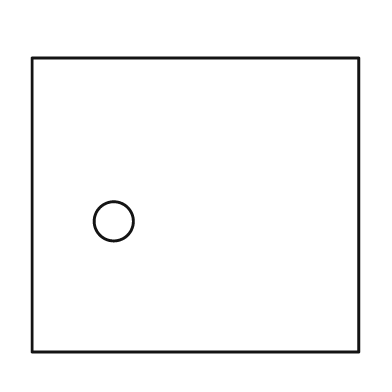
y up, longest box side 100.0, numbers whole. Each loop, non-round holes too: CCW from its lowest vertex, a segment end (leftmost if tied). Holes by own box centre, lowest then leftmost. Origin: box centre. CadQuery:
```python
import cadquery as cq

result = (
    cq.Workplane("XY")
    .moveTo(-50.0, -45.0)
    .lineTo(50.0, -45.0)
    .lineTo(50.0, 45.0)
    .lineTo(-50.0, 45.0)
    .close()
    .moveTo(-25.0, -5.0)
    .circle(6.0)
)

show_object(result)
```